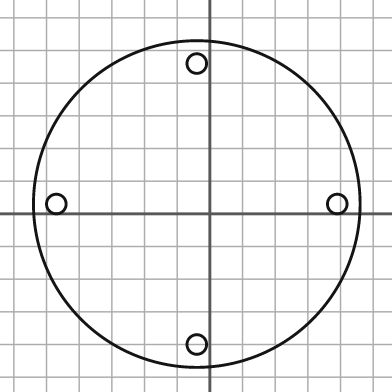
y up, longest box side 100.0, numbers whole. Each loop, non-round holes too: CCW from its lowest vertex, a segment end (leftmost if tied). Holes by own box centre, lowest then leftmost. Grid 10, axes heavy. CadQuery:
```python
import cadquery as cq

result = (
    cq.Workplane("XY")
    .moveTo(-4.0, 3.0)
    .circle(50.0)
    .moveTo(-4.0, -40.0)
    .circle(3.0)
    .moveTo(-47.0, 3.0)
    .circle(3.0)
    .moveTo(39.0, 3.0)
    .circle(3.0)
    .moveTo(-4.0, 46.0)
    .circle(3.0)
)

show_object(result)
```